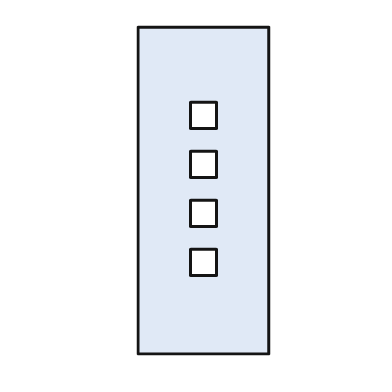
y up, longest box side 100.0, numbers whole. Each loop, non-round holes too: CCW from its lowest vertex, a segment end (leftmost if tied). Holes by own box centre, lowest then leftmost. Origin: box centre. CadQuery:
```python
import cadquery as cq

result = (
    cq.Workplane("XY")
    .moveTo(-20.0, -50.0)
    .lineTo(20.0, -50.0)
    .lineTo(20.0, 50.0)
    .lineTo(-20.0, 50.0)
    .close()
    .moveTo(-4.0, -26.0)
    .lineTo(4.0, -26.0)
    .lineTo(4.0, -18.0)
    .lineTo(-4.0, -18.0)
    .close()
    .moveTo(-4.0, -11.0)
    .lineTo(4.0, -11.0)
    .lineTo(4.0, -3.0)
    .lineTo(-4.0, -3.0)
    .close()
    .moveTo(-4.0, 4.0)
    .lineTo(4.0, 4.0)
    .lineTo(4.0, 12.0)
    .lineTo(-4.0, 12.0)
    .close()
    .moveTo(-4.0, 19.0)
    .lineTo(4.0, 19.0)
    .lineTo(4.0, 27.0)
    .lineTo(-4.0, 27.0)
    .close()
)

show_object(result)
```